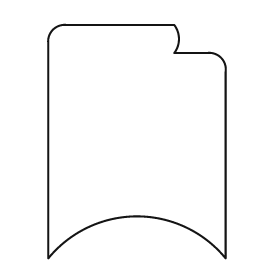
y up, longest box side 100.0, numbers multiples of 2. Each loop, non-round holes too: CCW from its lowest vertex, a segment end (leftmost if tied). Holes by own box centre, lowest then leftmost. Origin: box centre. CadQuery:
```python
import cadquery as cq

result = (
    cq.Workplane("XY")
    .moveTo(-38.0, -50.0)
    .threePointArc((0.0, -32.0), (38.0, -50.0))
    .lineTo(38.0, 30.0)
    .threePointArc((36.0, 36.0), (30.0, 38.0))
    .lineTo(16.0, 38.0)
    .threePointArc((18.0, 44.0), (16.0, 50.0))
    .lineTo(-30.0, 50.0)
    .threePointArc((-36.0, 48.0), (-38.0, 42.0))
    .close()
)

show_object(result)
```